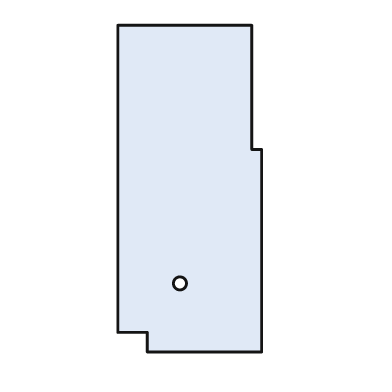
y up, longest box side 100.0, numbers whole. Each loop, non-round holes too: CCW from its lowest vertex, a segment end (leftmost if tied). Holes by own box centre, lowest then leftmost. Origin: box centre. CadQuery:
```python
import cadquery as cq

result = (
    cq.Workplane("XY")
    .moveTo(-13.0, -50.0)
    .lineTo(22.0, -50.0)
    .lineTo(22.0, 12.0)
    .lineTo(19.0, 12.0)
    .lineTo(19.0, 50.0)
    .lineTo(-22.0, 50.0)
    .lineTo(-22.0, -44.0)
    .lineTo(-13.0, -44.0)
    .close()
    .moveTo(-3.0, -29.0)
    .circle(2.0)
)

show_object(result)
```